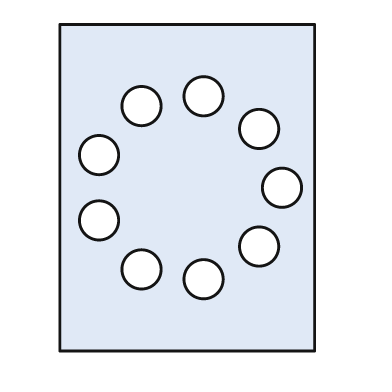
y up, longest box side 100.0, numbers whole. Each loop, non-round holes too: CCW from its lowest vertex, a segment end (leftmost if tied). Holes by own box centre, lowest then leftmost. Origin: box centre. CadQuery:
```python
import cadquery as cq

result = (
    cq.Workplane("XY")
    .moveTo(-39.0, -50.0)
    .lineTo(39.0, -50.0)
    .lineTo(39.0, 50.0)
    .lineTo(-39.0, 50.0)
    .close()
    .moveTo(5.0, -28.0)
    .circle(6.0)
    .moveTo(-14.0, -25.0)
    .circle(6.0)
    .moveTo(22.0, -18.0)
    .circle(6.0)
    .moveTo(-27.0, -10.0)
    .circle(6.0)
    .moveTo(29.0, 0.0)
    .circle(6.0)
    .moveTo(-27.0, 10.0)
    .circle(6.0)
    .moveTo(22.0, 18.0)
    .circle(6.0)
    .moveTo(-14.0, 25.0)
    .circle(6.0)
    .moveTo(5.0, 28.0)
    .circle(6.0)
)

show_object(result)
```